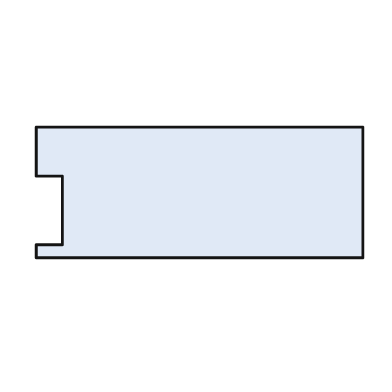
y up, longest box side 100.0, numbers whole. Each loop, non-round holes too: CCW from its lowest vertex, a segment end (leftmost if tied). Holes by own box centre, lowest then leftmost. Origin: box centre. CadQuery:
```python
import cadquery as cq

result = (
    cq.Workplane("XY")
    .moveTo(-50.0, -20.0)
    .lineTo(50.0, -20.0)
    .lineTo(50.0, 20.0)
    .lineTo(-50.0, 20.0)
    .lineTo(-50.0, 5.0)
    .lineTo(-42.0, 5.0)
    .lineTo(-42.0, -16.0)
    .lineTo(-50.0, -16.0)
    .close()
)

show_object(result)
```